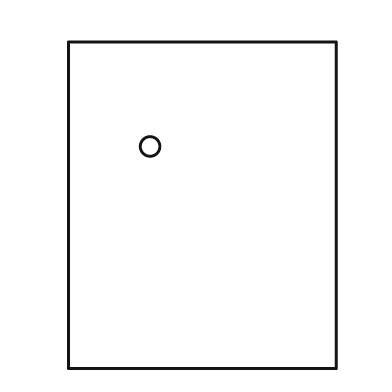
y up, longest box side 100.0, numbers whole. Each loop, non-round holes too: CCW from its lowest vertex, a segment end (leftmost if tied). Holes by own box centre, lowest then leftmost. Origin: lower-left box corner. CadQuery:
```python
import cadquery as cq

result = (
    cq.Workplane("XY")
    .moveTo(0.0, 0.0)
    .lineTo(82.0, 0.0)
    .lineTo(82.0, 100.0)
    .lineTo(0.0, 100.0)
    .close()
    .moveTo(25.0, 68.0)
    .circle(3.0)
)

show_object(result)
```